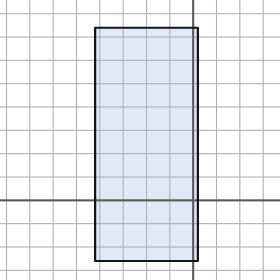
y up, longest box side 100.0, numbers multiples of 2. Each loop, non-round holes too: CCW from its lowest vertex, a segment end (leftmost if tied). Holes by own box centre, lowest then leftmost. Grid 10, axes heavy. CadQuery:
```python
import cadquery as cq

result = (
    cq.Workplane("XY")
    .moveTo(-42.0, -26.0)
    .lineTo(2.0, -26.0)
    .lineTo(2.0, 74.0)
    .lineTo(-42.0, 74.0)
    .close()
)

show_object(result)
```